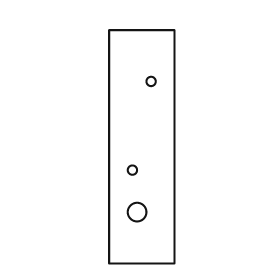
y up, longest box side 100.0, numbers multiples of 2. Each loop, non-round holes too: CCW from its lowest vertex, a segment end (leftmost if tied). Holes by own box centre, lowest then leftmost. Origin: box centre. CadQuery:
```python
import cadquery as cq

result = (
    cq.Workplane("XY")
    .moveTo(-14.0, -50.0)
    .lineTo(14.0, -50.0)
    .lineTo(14.0, 50.0)
    .lineTo(-14.0, 50.0)
    .close()
    .moveTo(-2.0, -28.0)
    .circle(4.0)
    .moveTo(-4.0, -10.0)
    .circle(2.0)
    .moveTo(4.0, 28.0)
    .circle(2.0)
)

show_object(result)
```